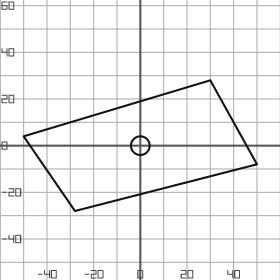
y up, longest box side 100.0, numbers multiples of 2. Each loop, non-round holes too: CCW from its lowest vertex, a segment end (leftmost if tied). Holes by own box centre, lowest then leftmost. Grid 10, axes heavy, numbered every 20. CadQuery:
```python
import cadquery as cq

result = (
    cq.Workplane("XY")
    .moveTo(-28.0, -28.0)
    .lineTo(50.0, -8.0)
    .lineTo(30.0, 28.0)
    .lineTo(-50.0, 4.0)
    .close()
    .moveTo(0.0, 0.0)
    .circle(4.0)
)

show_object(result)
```